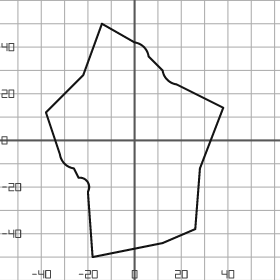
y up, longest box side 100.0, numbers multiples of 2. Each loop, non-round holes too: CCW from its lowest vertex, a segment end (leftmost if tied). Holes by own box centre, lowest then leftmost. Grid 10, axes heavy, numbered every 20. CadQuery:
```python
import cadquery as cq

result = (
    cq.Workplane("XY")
    .moveTo(-18.0, -50.0)
    .lineTo(12.0, -44.0)
    .lineTo(26.0, -38.0)
    .lineTo(28.0, -12.0)
    .lineTo(38.0, 14.0)
    .lineTo(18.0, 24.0)
    .threePointArc((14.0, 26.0), (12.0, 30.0))
    .lineTo(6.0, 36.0)
    .threePointArc((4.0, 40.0), (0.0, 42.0))
    .lineTo(-14.0, 50.0)
    .lineTo(-22.0, 28.0)
    .lineTo(-38.0, 12.0)
    .lineTo(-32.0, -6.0)
    .threePointArc((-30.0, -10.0), (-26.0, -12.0))
    .lineTo(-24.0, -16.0)
    .threePointArc((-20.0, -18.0), (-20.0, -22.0))
    .close()
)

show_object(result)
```